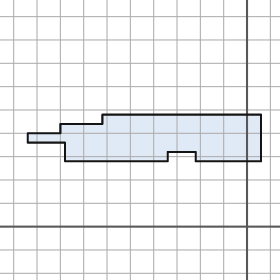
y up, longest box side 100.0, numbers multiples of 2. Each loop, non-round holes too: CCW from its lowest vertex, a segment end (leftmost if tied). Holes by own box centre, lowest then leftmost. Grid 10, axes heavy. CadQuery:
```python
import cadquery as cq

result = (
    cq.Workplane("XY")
    .moveTo(-78.0, 28.0)
    .lineTo(-34.0, 28.0)
    .lineTo(-34.0, 32.0)
    .lineTo(-22.0, 32.0)
    .lineTo(-22.0, 28.0)
    .lineTo(6.0, 28.0)
    .lineTo(6.0, 48.0)
    .lineTo(-62.0, 48.0)
    .lineTo(-62.0, 44.0)
    .lineTo(-80.0, 44.0)
    .lineTo(-80.0, 40.0)
    .lineTo(-94.0, 40.0)
    .lineTo(-94.0, 36.0)
    .lineTo(-78.0, 36.0)
    .close()
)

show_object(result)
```